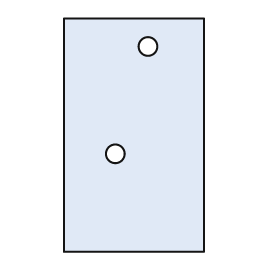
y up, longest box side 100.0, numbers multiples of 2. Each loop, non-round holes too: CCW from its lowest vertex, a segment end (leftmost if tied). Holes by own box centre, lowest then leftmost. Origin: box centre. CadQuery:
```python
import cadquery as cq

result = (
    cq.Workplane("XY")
    .moveTo(-30.0, -50.0)
    .lineTo(30.0, -50.0)
    .lineTo(30.0, 50.0)
    .lineTo(-30.0, 50.0)
    .close()
    .moveTo(-8.0, -8.0)
    .circle(4.0)
    .moveTo(6.0, 38.0)
    .circle(4.0)
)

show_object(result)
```